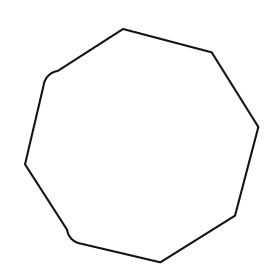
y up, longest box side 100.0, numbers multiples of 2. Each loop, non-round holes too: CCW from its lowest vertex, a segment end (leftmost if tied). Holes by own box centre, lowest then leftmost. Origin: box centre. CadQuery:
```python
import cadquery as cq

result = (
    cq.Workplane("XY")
    .moveTo(8.0, -50.0)
    .lineTo(40.0, -30.0)
    .lineTo(50.0, 8.0)
    .lineTo(30.0, 40.0)
    .lineTo(-8.0, 50.0)
    .lineTo(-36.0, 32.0)
    .threePointArc((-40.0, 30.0), (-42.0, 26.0))
    .lineTo(-50.0, -8.0)
    .lineTo(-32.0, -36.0)
    .threePointArc((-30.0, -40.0), (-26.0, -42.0))
    .close()
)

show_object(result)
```